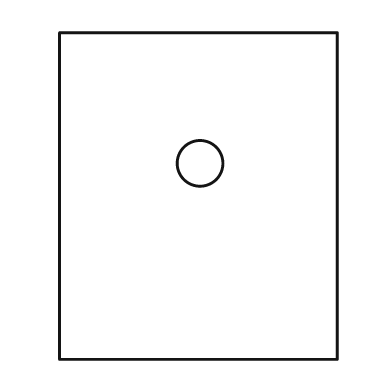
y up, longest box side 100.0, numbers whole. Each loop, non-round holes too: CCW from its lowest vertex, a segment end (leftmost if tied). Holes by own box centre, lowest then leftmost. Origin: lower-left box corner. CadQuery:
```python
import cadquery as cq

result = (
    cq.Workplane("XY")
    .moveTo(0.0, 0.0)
    .lineTo(85.0, 0.0)
    .lineTo(85.0, 100.0)
    .lineTo(0.0, 100.0)
    .close()
    .moveTo(43.0, 60.0)
    .circle(7.0)
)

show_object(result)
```